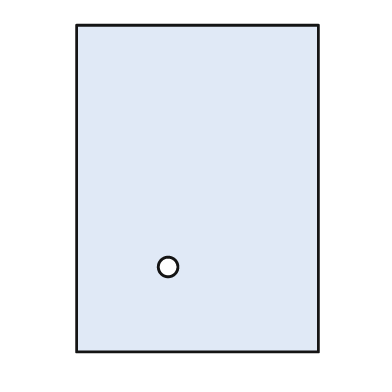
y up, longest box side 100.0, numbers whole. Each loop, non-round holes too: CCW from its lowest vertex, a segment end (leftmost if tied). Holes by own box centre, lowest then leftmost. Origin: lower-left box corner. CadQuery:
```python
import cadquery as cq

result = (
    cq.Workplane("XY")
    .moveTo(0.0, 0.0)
    .lineTo(74.0, 0.0)
    .lineTo(74.0, 100.0)
    .lineTo(0.0, 100.0)
    .close()
    .moveTo(28.0, 26.0)
    .circle(3.0)
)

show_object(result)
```